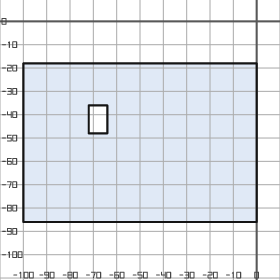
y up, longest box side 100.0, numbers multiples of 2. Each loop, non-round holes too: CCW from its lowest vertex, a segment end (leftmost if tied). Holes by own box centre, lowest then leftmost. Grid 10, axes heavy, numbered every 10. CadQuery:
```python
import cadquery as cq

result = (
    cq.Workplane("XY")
    .moveTo(-100.0, -86.0)
    .lineTo(0.0, -86.0)
    .lineTo(0.0, -18.0)
    .lineTo(-100.0, -18.0)
    .close()
    .moveTo(-72.0, -48.0)
    .lineTo(-64.0, -48.0)
    .lineTo(-64.0, -36.0)
    .lineTo(-72.0, -36.0)
    .close()
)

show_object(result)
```